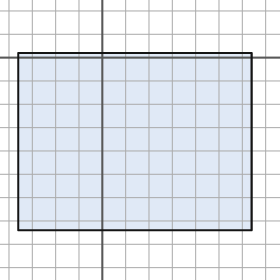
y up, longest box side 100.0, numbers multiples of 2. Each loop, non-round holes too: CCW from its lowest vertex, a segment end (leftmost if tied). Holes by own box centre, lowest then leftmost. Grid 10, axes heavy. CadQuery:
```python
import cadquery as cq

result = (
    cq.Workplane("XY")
    .moveTo(-36.0, -74.0)
    .lineTo(64.0, -74.0)
    .lineTo(64.0, 2.0)
    .lineTo(-36.0, 2.0)
    .close()
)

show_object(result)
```